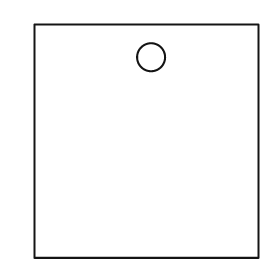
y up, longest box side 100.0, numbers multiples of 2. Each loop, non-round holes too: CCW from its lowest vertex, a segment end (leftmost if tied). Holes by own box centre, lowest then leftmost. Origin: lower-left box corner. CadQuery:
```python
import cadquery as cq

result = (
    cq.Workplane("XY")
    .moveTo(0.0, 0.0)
    .lineTo(96.0, 0.0)
    .lineTo(96.0, 100.0)
    .lineTo(0.0, 100.0)
    .close()
    .moveTo(50.0, 86.0)
    .circle(6.0)
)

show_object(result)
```